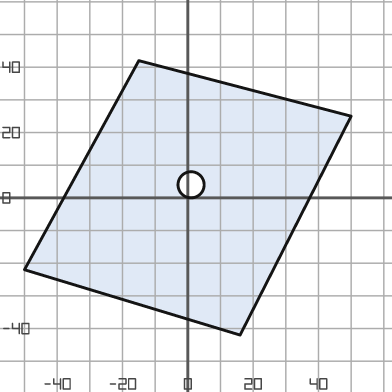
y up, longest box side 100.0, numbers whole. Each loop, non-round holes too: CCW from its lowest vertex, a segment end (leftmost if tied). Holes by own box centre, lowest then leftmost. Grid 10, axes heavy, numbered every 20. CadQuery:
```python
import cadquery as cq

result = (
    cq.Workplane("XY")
    .moveTo(16.0, -42.0)
    .lineTo(50.0, 25.0)
    .lineTo(-15.0, 42.0)
    .lineTo(-50.0, -22.0)
    .close()
    .moveTo(1.0, 4.0)
    .circle(4.0)
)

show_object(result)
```